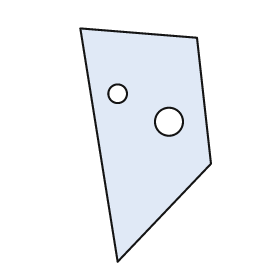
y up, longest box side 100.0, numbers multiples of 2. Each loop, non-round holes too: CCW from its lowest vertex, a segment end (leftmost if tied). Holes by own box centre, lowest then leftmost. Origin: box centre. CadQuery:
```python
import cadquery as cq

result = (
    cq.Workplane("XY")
    .moveTo(-12.0, -50.0)
    .lineTo(28.0, -8.0)
    .lineTo(22.0, 46.0)
    .lineTo(-28.0, 50.0)
    .close()
    .moveTo(10.0, 10.0)
    .circle(6.0)
    .moveTo(-12.0, 22.0)
    .circle(4.0)
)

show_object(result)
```